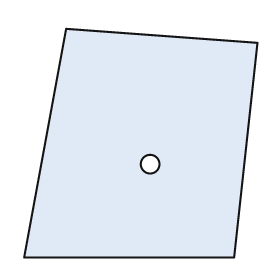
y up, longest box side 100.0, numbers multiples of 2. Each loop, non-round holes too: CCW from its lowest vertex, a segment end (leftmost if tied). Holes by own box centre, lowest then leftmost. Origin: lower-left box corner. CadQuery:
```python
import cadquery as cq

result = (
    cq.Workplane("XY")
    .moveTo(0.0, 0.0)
    .lineTo(90.0, 0.0)
    .lineTo(100.0, 92.0)
    .lineTo(18.0, 98.0)
    .close()
    .moveTo(54.0, 40.0)
    .circle(4.0)
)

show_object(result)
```